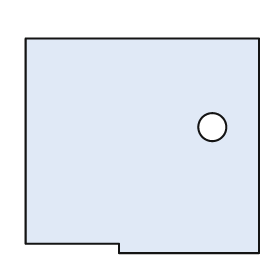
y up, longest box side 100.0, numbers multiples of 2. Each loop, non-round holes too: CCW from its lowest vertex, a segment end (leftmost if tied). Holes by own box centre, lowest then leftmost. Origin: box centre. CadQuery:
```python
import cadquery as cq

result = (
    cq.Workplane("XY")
    .moveTo(-10.0, -46.0)
    .lineTo(50.0, -46.0)
    .lineTo(50.0, 46.0)
    .lineTo(-50.0, 46.0)
    .lineTo(-50.0, -42.0)
    .lineTo(-10.0, -42.0)
    .close()
    .moveTo(30.0, 8.0)
    .circle(6.0)
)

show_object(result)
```